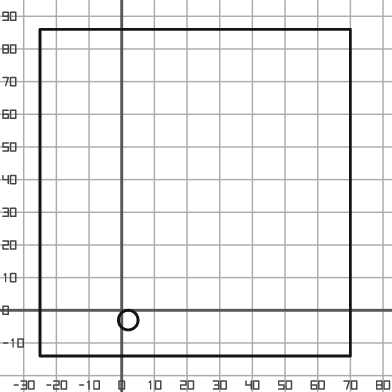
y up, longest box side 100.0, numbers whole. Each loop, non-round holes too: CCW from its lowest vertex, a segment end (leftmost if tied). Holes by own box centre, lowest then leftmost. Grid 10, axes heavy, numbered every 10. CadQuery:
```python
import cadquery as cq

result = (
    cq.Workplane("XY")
    .moveTo(-25.0, -14.0)
    .lineTo(70.0, -14.0)
    .lineTo(70.0, 86.0)
    .lineTo(-25.0, 86.0)
    .close()
    .moveTo(2.0, -3.0)
    .circle(3.0)
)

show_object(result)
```